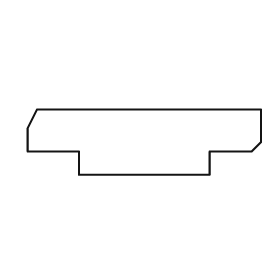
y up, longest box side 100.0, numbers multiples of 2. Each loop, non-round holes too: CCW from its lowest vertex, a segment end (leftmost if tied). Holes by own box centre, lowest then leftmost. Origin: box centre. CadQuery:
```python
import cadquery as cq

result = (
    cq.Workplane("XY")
    .moveTo(-28.0, -14.0)
    .lineTo(28.0, -14.0)
    .lineTo(28.0, -4.0)
    .lineTo(46.0, -4.0)
    .lineTo(50.0, 0.0)
    .lineTo(50.0, 14.0)
    .lineTo(-46.0, 14.0)
    .lineTo(-50.0, 6.0)
    .lineTo(-50.0, -4.0)
    .lineTo(-28.0, -4.0)
    .close()
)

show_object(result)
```